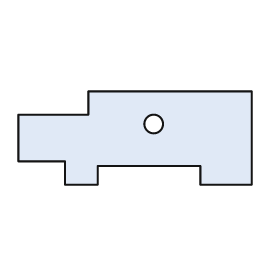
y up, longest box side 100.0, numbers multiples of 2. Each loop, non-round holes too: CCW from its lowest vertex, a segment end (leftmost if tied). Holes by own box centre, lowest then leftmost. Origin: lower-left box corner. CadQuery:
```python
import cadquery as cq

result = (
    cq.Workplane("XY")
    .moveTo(20.0, 0.0)
    .lineTo(34.0, 0.0)
    .lineTo(34.0, 8.0)
    .lineTo(78.0, 8.0)
    .lineTo(78.0, 0.0)
    .lineTo(100.0, 0.0)
    .lineTo(100.0, 40.0)
    .lineTo(30.0, 40.0)
    .lineTo(30.0, 30.0)
    .lineTo(0.0, 30.0)
    .lineTo(0.0, 10.0)
    .lineTo(20.0, 10.0)
    .close()
    .moveTo(58.0, 26.0)
    .circle(4.0)
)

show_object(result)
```